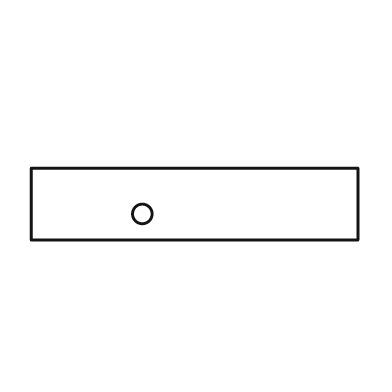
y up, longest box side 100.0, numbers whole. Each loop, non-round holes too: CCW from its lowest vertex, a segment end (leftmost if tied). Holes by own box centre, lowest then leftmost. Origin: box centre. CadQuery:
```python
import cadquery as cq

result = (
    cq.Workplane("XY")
    .moveTo(-50.0, -11.0)
    .lineTo(50.0, -11.0)
    .lineTo(50.0, 11.0)
    .lineTo(-50.0, 11.0)
    .close()
    .moveTo(-16.0, -3.0)
    .circle(3.0)
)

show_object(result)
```